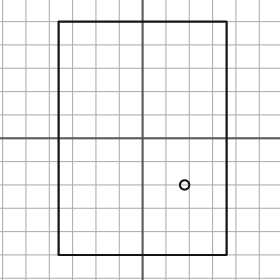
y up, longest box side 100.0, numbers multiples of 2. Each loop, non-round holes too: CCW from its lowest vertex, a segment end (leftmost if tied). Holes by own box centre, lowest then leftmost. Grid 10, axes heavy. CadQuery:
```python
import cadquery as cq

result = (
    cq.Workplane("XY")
    .moveTo(-36.0, -50.0)
    .lineTo(36.0, -50.0)
    .lineTo(36.0, 50.0)
    .lineTo(-36.0, 50.0)
    .close()
    .moveTo(18.0, -20.0)
    .circle(2.0)
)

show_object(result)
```